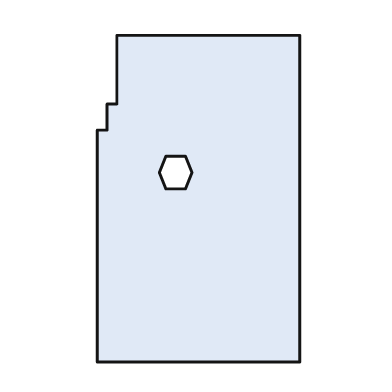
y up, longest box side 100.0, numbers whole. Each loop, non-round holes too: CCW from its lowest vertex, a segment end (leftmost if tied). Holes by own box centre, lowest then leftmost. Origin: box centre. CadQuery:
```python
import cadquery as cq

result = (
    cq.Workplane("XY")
    .moveTo(-31.0, -50.0)
    .lineTo(31.0, -50.0)
    .lineTo(31.0, 50.0)
    .lineTo(-25.0, 50.0)
    .lineTo(-25.0, 29.0)
    .lineTo(-28.0, 29.0)
    .lineTo(-28.0, 21.0)
    .lineTo(-31.0, 21.0)
    .close()
    .moveTo(-10.0, 3.0)
    .lineTo(-4.0, 3.0)
    .lineTo(-2.0, 8.0)
    .lineTo(-4.0, 13.0)
    .lineTo(-10.0, 13.0)
    .lineTo(-12.0, 8.0)
    .close()
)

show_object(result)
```